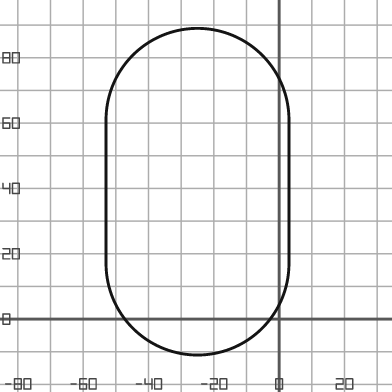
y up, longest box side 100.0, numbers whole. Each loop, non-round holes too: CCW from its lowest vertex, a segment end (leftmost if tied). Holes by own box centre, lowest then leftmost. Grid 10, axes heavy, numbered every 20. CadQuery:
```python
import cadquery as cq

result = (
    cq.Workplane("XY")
    .moveTo(-53.0, 17.0)
    .threePointArc((-25.0, -11.0), (3.0, 17.0))
    .lineTo(3.0, 61.0)
    .threePointArc((-25.0, 89.0), (-53.0, 61.0))
    .close()
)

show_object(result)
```